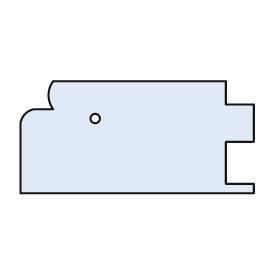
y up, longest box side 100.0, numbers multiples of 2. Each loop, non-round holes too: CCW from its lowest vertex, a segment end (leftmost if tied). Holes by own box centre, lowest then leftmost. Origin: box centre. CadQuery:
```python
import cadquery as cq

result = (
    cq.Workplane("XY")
    .moveTo(-50.0, -24.0)
    .lineTo(50.0, -24.0)
    .lineTo(50.0, -20.0)
    .lineTo(38.0, -20.0)
    .lineTo(38.0, -2.0)
    .lineTo(50.0, -2.0)
    .lineTo(50.0, 14.0)
    .lineTo(38.0, 14.0)
    .lineTo(38.0, 24.0)
    .lineTo(-36.0, 24.0)
    .threePointArc((-38.0, 18.0), (-36.0, 12.0))
    .lineTo(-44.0, 12.0)
    .threePointArc((-48.0, 10.0), (-50.0, 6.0))
    .close()
    .moveTo(-18.0, 8.0)
    .circle(2.0)
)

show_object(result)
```